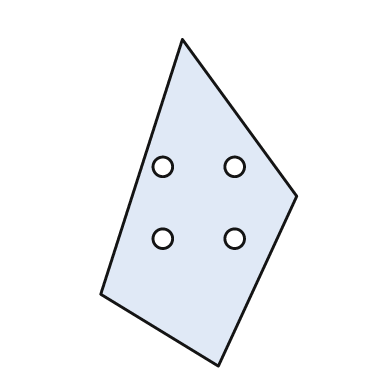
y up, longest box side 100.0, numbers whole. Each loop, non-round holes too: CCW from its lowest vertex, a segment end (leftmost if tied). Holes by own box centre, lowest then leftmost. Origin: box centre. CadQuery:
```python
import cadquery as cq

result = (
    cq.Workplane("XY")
    .moveTo(6.0, -50.0)
    .lineTo(30.0, 2.0)
    .lineTo(-5.0, 50.0)
    .lineTo(-30.0, -28.0)
    .close()
    .moveTo(-11.0, -11.0)
    .circle(3.0)
    .moveTo(11.0, -11.0)
    .circle(3.0)
    .moveTo(-11.0, 11.0)
    .circle(3.0)
    .moveTo(11.0, 11.0)
    .circle(3.0)
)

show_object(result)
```